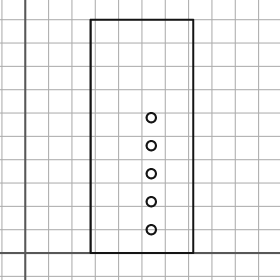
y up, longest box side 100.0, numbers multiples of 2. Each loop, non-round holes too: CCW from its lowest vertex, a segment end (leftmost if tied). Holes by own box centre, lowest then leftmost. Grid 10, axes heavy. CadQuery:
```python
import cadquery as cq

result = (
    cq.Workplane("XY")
    .moveTo(28.0, 0.0)
    .lineTo(72.0, 0.0)
    .lineTo(72.0, 100.0)
    .lineTo(28.0, 100.0)
    .close()
    .moveTo(54.0, 10.0)
    .circle(2.0)
    .moveTo(54.0, 22.0)
    .circle(2.0)
    .moveTo(54.0, 34.0)
    .circle(2.0)
    .moveTo(54.0, 46.0)
    .circle(2.0)
    .moveTo(54.0, 58.0)
    .circle(2.0)
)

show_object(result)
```